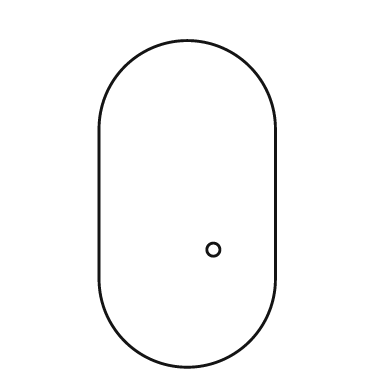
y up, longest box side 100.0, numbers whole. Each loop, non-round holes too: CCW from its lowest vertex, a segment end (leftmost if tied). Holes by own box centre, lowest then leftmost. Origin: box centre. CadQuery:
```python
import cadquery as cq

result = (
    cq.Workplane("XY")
    .moveTo(-27.0, -23.0)
    .threePointArc((0.0, -50.0), (27.0, -23.0))
    .lineTo(27.0, 23.0)
    .threePointArc((0.0, 50.0), (-27.0, 23.0))
    .close()
    .moveTo(8.0, -14.0)
    .circle(2.0)
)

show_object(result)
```